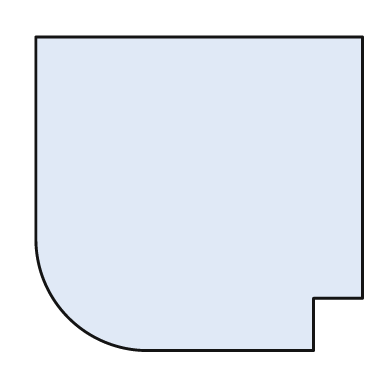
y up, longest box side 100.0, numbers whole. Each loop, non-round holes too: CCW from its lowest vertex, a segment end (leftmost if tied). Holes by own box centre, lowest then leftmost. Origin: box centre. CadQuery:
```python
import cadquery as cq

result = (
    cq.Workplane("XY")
    .moveTo(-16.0, -48.0)
    .lineTo(35.0, -48.0)
    .lineTo(35.0, -32.0)
    .lineTo(50.0, -32.0)
    .lineTo(50.0, 48.0)
    .lineTo(-50.0, 48.0)
    .lineTo(-50.0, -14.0)
    .threePointArc((-40.0, -38.0), (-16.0, -48.0))
    .close()
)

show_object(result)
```